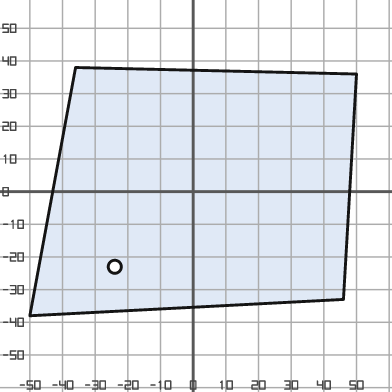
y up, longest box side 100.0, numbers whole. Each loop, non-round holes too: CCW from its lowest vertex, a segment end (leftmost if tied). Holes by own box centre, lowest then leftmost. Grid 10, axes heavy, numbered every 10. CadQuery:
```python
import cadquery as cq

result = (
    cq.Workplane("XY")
    .moveTo(-50.0, -38.0)
    .lineTo(46.0, -33.0)
    .lineTo(50.0, 36.0)
    .lineTo(-36.0, 38.0)
    .close()
    .moveTo(-24.0, -23.0)
    .circle(2.0)
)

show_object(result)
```